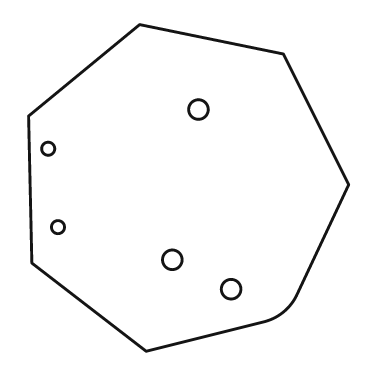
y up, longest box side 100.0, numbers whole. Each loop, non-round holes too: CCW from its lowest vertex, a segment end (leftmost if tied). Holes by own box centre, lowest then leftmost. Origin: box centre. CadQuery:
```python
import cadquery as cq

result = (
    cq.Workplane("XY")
    .moveTo(-13.0, -50.0)
    .lineTo(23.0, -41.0)
    .threePointArc((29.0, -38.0), (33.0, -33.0))
    .lineTo(49.0, 1.0)
    .lineTo(29.0, 41.0)
    .lineTo(-15.0, 50.0)
    .lineTo(-49.0, 22.0)
    .lineTo(-48.0, -23.0)
    .close()
    .moveTo(13.0, -31.0)
    .circle(3.0)
    .moveTo(-5.0, -22.0)
    .circle(3.0)
    .moveTo(-40.0, -12.0)
    .circle(2.0)
    .moveTo(-43.0, 12.0)
    .circle(2.0)
    .moveTo(3.0, 24.0)
    .circle(3.0)
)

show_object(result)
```